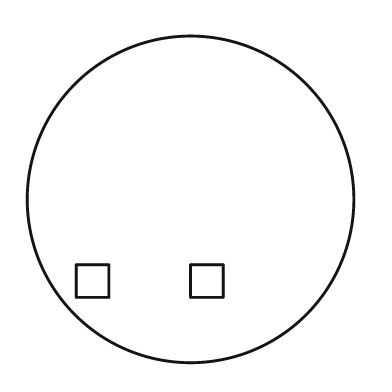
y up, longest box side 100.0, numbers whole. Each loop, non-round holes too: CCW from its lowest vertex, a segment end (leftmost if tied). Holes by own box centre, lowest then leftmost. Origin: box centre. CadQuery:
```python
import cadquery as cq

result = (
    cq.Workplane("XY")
    .moveTo(0.0, 0.0)
    .circle(50.0)
    .moveTo(-35.0, -30.0)
    .lineTo(-25.0, -30.0)
    .lineTo(-25.0, -20.0)
    .lineTo(-35.0, -20.0)
    .close()
    .moveTo(0.0, -30.0)
    .lineTo(10.0, -30.0)
    .lineTo(10.0, -20.0)
    .lineTo(0.0, -20.0)
    .close()
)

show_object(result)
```